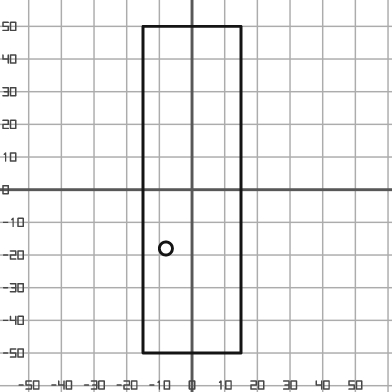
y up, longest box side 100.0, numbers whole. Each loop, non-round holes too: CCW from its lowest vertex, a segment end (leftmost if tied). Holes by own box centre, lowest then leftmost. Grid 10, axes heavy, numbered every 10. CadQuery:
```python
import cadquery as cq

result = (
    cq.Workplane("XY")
    .moveTo(-15.0, -50.0)
    .lineTo(15.0, -50.0)
    .lineTo(15.0, 50.0)
    .lineTo(-15.0, 50.0)
    .close()
    .moveTo(-8.0, -18.0)
    .circle(2.0)
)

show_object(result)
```